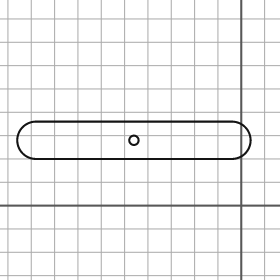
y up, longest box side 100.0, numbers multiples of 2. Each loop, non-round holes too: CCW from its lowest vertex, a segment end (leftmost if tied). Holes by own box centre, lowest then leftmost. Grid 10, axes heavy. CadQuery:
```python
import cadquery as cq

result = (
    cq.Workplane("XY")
    .moveTo(-88.0, 20.0)
    .lineTo(-4.0, 20.0)
    .threePointArc((4.0, 28.0), (-4.0, 36.0))
    .lineTo(-88.0, 36.0)
    .threePointArc((-96.0, 28.0), (-88.0, 20.0))
    .close()
    .moveTo(-46.0, 28.0)
    .circle(2.0)
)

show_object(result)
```